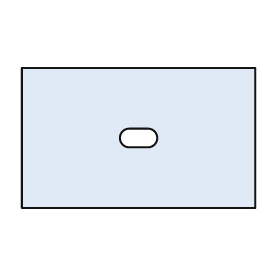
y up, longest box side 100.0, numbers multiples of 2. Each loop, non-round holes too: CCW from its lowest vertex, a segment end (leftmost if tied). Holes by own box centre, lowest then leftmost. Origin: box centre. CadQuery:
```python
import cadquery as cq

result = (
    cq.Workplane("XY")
    .moveTo(-50.0, -30.0)
    .lineTo(50.0, -30.0)
    .lineTo(50.0, 30.0)
    .lineTo(-50.0, 30.0)
    .close()
    .moveTo(-4.0, -4.0)
    .lineTo(4.0, -4.0)
    .threePointArc((8.0, 0.0), (4.0, 4.0))
    .lineTo(-4.0, 4.0)
    .threePointArc((-8.0, 0.0), (-4.0, -4.0))
    .close()
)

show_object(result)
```